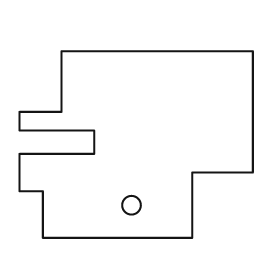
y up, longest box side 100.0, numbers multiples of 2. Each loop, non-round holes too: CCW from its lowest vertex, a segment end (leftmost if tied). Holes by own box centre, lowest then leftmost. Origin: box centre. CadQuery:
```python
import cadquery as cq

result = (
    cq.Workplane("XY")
    .moveTo(-40.0, -40.0)
    .lineTo(24.0, -40.0)
    .lineTo(24.0, -12.0)
    .lineTo(50.0, -12.0)
    .lineTo(50.0, 40.0)
    .lineTo(-32.0, 40.0)
    .lineTo(-32.0, 14.0)
    .lineTo(-50.0, 14.0)
    .lineTo(-50.0, 6.0)
    .lineTo(-18.0, 6.0)
    .lineTo(-18.0, -4.0)
    .lineTo(-50.0, -4.0)
    .lineTo(-50.0, -20.0)
    .lineTo(-40.0, -20.0)
    .close()
    .moveTo(-2.0, -26.0)
    .circle(4.0)
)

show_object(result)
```